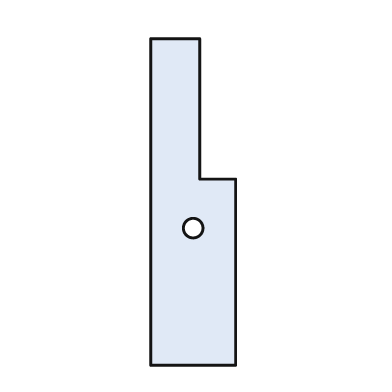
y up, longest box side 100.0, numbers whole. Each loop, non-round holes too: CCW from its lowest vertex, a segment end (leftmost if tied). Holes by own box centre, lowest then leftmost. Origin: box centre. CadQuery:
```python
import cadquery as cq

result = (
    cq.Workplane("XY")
    .moveTo(-13.0, -50.0)
    .lineTo(13.0, -50.0)
    .lineTo(13.0, 7.0)
    .lineTo(2.0, 7.0)
    .lineTo(2.0, 50.0)
    .lineTo(-13.0, 50.0)
    .close()
    .moveTo(0.0, -8.0)
    .circle(3.0)
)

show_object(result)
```